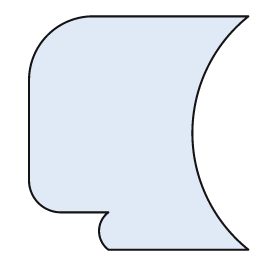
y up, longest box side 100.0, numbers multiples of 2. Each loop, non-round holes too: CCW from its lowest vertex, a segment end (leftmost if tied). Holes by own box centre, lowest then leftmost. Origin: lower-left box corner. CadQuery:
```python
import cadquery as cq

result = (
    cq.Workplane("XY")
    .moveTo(34.0, 0.0)
    .lineTo(94.0, 0.0)
    .threePointArc((70.0, 50.0), (94.0, 100.0))
    .lineTo(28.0, 100.0)
    .threePointArc((8.0, 92.0), (0.0, 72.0))
    .lineTo(0.0, 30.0)
    .threePointArc((4.0, 20.0), (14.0, 16.0))
    .lineTo(34.0, 16.0)
    .threePointArc((30.0, 8.0), (34.0, 0.0))
    .close()
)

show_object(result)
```